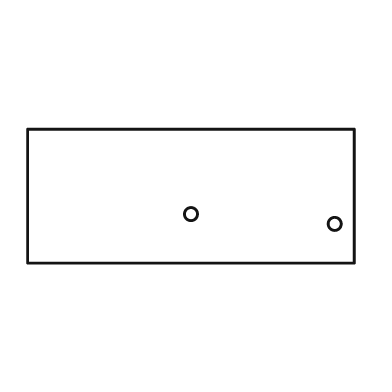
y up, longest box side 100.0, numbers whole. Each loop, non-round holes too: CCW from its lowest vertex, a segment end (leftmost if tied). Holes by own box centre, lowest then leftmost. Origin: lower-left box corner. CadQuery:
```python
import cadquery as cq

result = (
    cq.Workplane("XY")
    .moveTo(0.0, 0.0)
    .lineTo(100.0, 0.0)
    .lineTo(100.0, 41.0)
    .lineTo(0.0, 41.0)
    .close()
    .moveTo(94.0, 12.0)
    .circle(2.0)
    .moveTo(50.0, 15.0)
    .circle(2.0)
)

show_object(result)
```